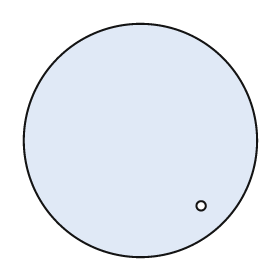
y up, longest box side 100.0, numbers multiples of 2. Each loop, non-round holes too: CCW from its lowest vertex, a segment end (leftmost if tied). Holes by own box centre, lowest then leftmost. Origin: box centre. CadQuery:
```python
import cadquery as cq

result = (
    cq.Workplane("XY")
    .moveTo(0.0, 0.0)
    .circle(50.0)
    .moveTo(26.0, -28.0)
    .circle(2.0)
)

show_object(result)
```